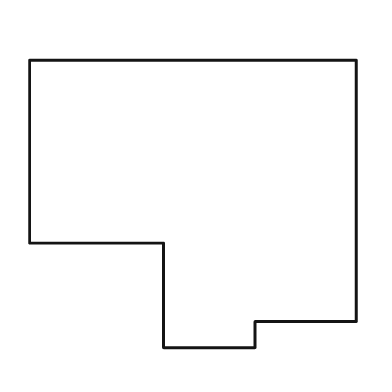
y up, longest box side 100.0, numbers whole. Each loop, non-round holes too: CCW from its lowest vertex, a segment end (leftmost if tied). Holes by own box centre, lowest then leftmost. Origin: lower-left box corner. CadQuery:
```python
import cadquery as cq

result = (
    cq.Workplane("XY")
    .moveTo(41.0, 0.0)
    .lineTo(69.0, 0.0)
    .lineTo(69.0, 8.0)
    .lineTo(100.0, 8.0)
    .lineTo(100.0, 88.0)
    .lineTo(0.0, 88.0)
    .lineTo(0.0, 32.0)
    .lineTo(41.0, 32.0)
    .close()
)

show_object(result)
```